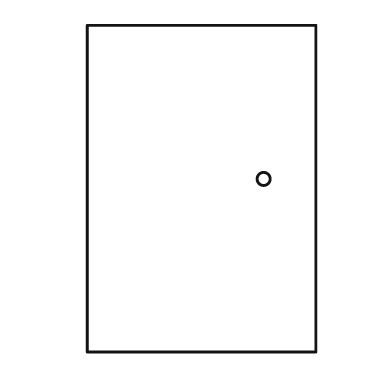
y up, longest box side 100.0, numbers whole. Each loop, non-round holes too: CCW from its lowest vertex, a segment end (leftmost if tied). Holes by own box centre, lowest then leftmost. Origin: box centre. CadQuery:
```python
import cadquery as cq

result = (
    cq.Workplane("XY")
    .moveTo(-35.0, -50.0)
    .lineTo(35.0, -50.0)
    .lineTo(35.0, 50.0)
    .lineTo(-35.0, 50.0)
    .close()
    .moveTo(19.0, 3.0)
    .circle(2.0)
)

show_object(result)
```